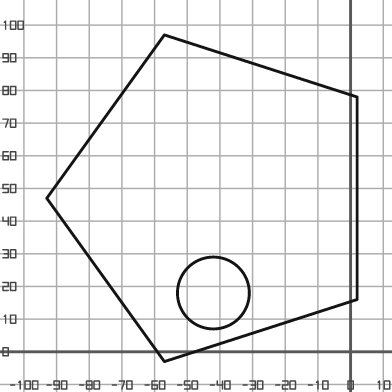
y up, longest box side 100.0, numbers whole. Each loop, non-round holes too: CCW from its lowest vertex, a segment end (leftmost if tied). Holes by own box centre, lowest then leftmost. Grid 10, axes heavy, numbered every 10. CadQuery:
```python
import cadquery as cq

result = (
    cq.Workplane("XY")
    .moveTo(-57.0, -3.0)
    .lineTo(2.0, 16.0)
    .lineTo(2.0, 78.0)
    .lineTo(-57.0, 97.0)
    .lineTo(-93.0, 47.0)
    .close()
    .moveTo(-42.0, 18.0)
    .circle(11.0)
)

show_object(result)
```